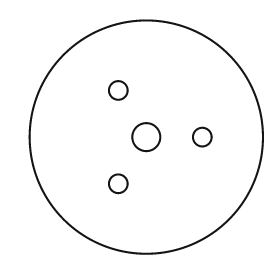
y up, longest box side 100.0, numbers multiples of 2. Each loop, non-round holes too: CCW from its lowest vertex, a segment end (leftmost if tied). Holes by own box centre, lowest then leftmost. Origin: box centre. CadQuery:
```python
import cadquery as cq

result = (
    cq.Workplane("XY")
    .moveTo(0.0, 0.0)
    .circle(50.0)
    .moveTo(-12.0, -20.0)
    .circle(4.0)
    .moveTo(0.0, 0.0)
    .circle(6.0)
    .moveTo(24.0, 0.0)
    .circle(4.0)
    .moveTo(-12.0, 20.0)
    .circle(4.0)
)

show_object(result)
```